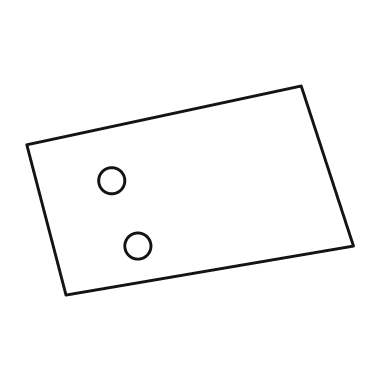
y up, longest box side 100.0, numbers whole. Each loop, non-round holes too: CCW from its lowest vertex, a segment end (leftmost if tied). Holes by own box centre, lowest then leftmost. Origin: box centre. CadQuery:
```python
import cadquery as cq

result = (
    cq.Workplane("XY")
    .moveTo(-38.0, -32.0)
    .lineTo(50.0, -17.0)
    .lineTo(34.0, 32.0)
    .lineTo(-50.0, 14.0)
    .close()
    .moveTo(-16.0, -17.0)
    .circle(4.0)
    .moveTo(-24.0, 3.0)
    .circle(4.0)
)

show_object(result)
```